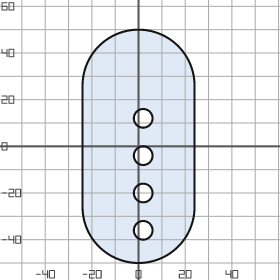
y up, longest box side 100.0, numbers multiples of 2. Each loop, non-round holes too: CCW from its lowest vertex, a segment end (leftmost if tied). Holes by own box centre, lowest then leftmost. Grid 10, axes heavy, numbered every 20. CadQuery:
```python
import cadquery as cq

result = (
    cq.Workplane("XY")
    .moveTo(-24.0, -26.0)
    .threePointArc((0.0, -50.0), (24.0, -26.0))
    .lineTo(24.0, 26.0)
    .threePointArc((0.0, 50.0), (-24.0, 26.0))
    .close()
    .moveTo(2.0, -36.0)
    .circle(4.0)
    .moveTo(2.0, -20.0)
    .circle(4.0)
    .moveTo(2.0, -4.0)
    .circle(4.0)
    .moveTo(2.0, 12.0)
    .circle(4.0)
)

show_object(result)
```